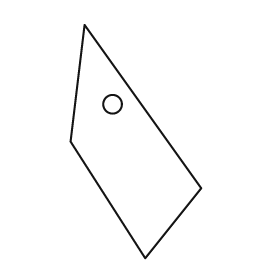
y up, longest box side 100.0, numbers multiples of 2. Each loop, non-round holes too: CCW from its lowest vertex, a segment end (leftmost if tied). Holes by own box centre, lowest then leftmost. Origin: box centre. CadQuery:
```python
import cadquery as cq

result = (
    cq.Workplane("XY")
    .moveTo(4.0, -50.0)
    .lineTo(28.0, -20.0)
    .lineTo(-22.0, 50.0)
    .lineTo(-28.0, 0.0)
    .close()
    .moveTo(-10.0, 16.0)
    .circle(4.0)
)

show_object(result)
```